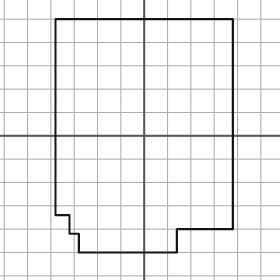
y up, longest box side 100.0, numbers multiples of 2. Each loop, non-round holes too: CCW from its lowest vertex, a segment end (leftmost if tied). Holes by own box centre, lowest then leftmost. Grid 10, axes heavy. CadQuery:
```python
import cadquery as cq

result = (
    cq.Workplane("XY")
    .moveTo(-28.0, -50.0)
    .lineTo(14.0, -50.0)
    .lineTo(14.0, -40.0)
    .lineTo(38.0, -40.0)
    .lineTo(38.0, 50.0)
    .lineTo(-38.0, 50.0)
    .lineTo(-38.0, -34.0)
    .lineTo(-32.0, -34.0)
    .lineTo(-32.0, -42.0)
    .lineTo(-28.0, -42.0)
    .close()
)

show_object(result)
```